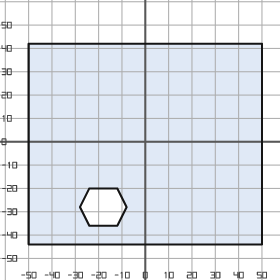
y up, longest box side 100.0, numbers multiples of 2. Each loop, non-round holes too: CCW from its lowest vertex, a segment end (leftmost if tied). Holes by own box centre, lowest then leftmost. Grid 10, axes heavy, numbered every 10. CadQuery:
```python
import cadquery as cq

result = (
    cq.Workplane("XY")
    .moveTo(-50.0, -44.0)
    .lineTo(50.0, -44.0)
    .lineTo(50.0, 42.0)
    .lineTo(-50.0, 42.0)
    .close()
    .moveTo(-24.0, -36.0)
    .lineTo(-12.0, -36.0)
    .lineTo(-8.0, -28.0)
    .lineTo(-12.0, -20.0)
    .lineTo(-24.0, -20.0)
    .lineTo(-28.0, -28.0)
    .close()
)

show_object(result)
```